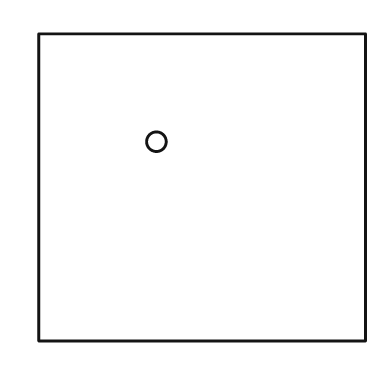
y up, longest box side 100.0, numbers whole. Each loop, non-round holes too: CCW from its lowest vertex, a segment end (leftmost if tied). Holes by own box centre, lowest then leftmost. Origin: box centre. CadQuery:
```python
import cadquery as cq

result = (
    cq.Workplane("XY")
    .moveTo(-50.0, -47.0)
    .lineTo(50.0, -47.0)
    .lineTo(50.0, 47.0)
    .lineTo(-50.0, 47.0)
    .close()
    .moveTo(-14.0, 14.0)
    .circle(3.0)
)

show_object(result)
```